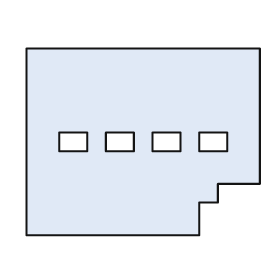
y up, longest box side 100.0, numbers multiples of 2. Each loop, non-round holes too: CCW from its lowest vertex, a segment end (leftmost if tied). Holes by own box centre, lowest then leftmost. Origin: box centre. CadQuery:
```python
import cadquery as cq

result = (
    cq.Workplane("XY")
    .moveTo(-50.0, -40.0)
    .lineTo(24.0, -40.0)
    .lineTo(24.0, -26.0)
    .lineTo(32.0, -26.0)
    .lineTo(32.0, -18.0)
    .lineTo(50.0, -18.0)
    .lineTo(50.0, 40.0)
    .lineTo(-50.0, 40.0)
    .close()
    .moveTo(-36.0, -4.0)
    .lineTo(-24.0, -4.0)
    .lineTo(-24.0, 4.0)
    .lineTo(-36.0, 4.0)
    .close()
    .moveTo(-16.0, -4.0)
    .lineTo(-4.0, -4.0)
    .lineTo(-4.0, 4.0)
    .lineTo(-16.0, 4.0)
    .close()
    .moveTo(4.0, -4.0)
    .lineTo(16.0, -4.0)
    .lineTo(16.0, 4.0)
    .lineTo(4.0, 4.0)
    .close()
    .moveTo(24.0, -4.0)
    .lineTo(36.0, -4.0)
    .lineTo(36.0, 4.0)
    .lineTo(24.0, 4.0)
    .close()
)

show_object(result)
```